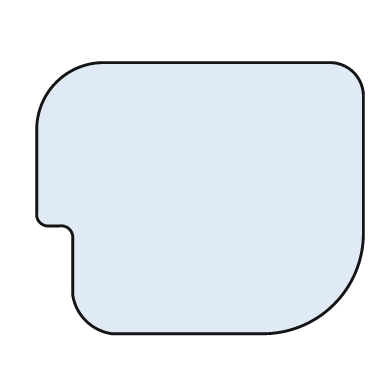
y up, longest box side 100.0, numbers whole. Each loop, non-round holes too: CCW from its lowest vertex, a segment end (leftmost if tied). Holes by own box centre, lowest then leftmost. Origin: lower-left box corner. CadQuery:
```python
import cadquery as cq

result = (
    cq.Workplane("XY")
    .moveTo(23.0, 0.0)
    .lineTo(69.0, 0.0)
    .threePointArc((91.0, 9.0), (100.0, 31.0))
    .lineTo(100.0, 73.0)
    .threePointArc((97.0, 80.0), (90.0, 83.0))
    .lineTo(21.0, 83.0)
    .threePointArc((6.0, 77.0), (0.0, 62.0))
    .lineTo(0.0, 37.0)
    .threePointArc((1.0, 34.0), (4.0, 33.0))
    .lineTo(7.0, 33.0)
    .threePointArc((10.0, 32.0), (11.0, 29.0))
    .lineTo(11.0, 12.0)
    .threePointArc((15.0, 4.0), (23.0, 0.0))
    .close()
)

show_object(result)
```